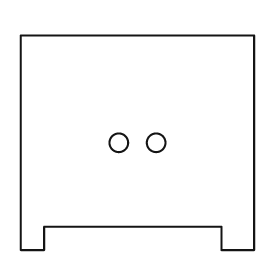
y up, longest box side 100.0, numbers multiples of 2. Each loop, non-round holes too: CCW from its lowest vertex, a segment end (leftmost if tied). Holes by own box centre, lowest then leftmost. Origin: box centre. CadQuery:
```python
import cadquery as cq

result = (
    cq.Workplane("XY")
    .moveTo(-50.0, -46.0)
    .lineTo(-40.0, -46.0)
    .lineTo(-40.0, -36.0)
    .lineTo(36.0, -36.0)
    .lineTo(36.0, -46.0)
    .lineTo(50.0, -46.0)
    .lineTo(50.0, 46.0)
    .lineTo(-50.0, 46.0)
    .close()
    .moveTo(-8.0, 0.0)
    .circle(4.0)
    .moveTo(8.0, 0.0)
    .circle(4.0)
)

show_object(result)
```